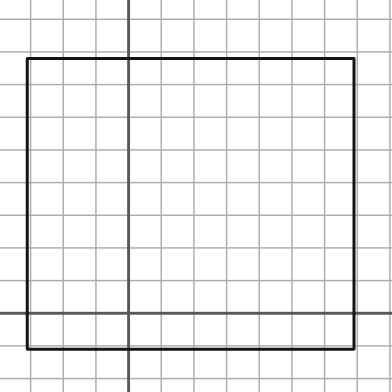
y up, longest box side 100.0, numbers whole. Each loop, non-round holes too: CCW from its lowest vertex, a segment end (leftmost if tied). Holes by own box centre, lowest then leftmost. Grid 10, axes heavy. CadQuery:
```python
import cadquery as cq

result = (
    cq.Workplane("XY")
    .moveTo(-31.0, -11.0)
    .lineTo(69.0, -11.0)
    .lineTo(69.0, 78.0)
    .lineTo(-31.0, 78.0)
    .close()
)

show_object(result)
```